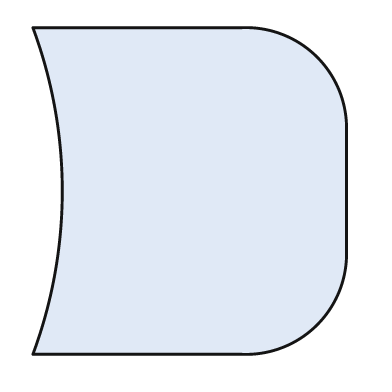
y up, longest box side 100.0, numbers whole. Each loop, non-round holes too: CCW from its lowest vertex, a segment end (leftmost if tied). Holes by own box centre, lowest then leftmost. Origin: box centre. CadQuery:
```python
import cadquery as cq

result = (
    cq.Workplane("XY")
    .moveTo(-48.0, -50.0)
    .lineTo(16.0, -50.0)
    .threePointArc((39.0, -41.0), (48.0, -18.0))
    .lineTo(48.0, 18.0)
    .threePointArc((39.0, 41.0), (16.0, 50.0))
    .lineTo(-48.0, 50.0)
    .threePointArc((-39.0, 0.0), (-48.0, -50.0))
    .close()
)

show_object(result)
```